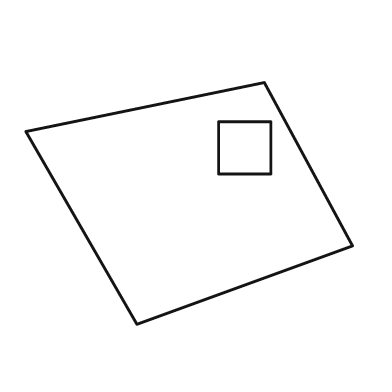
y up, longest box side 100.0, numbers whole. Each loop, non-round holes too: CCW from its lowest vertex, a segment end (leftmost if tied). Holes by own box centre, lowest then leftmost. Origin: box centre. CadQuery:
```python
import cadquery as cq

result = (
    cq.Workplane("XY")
    .moveTo(-16.0, -37.0)
    .lineTo(50.0, -13.0)
    .lineTo(23.0, 37.0)
    .lineTo(-50.0, 22.0)
    .close()
    .moveTo(9.0, 9.0)
    .lineTo(25.0, 9.0)
    .lineTo(25.0, 25.0)
    .lineTo(9.0, 25.0)
    .close()
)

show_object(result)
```